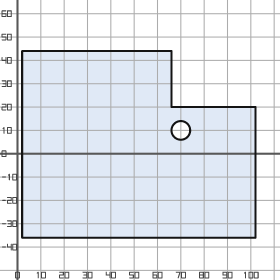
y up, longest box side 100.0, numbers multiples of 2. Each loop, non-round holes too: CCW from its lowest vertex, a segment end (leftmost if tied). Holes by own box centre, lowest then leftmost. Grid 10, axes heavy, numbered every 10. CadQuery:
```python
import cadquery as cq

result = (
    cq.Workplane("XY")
    .moveTo(2.0, -36.0)
    .lineTo(102.0, -36.0)
    .lineTo(102.0, 20.0)
    .lineTo(66.0, 20.0)
    .lineTo(66.0, 44.0)
    .lineTo(2.0, 44.0)
    .close()
    .moveTo(70.0, 10.0)
    .circle(4.0)
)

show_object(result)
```